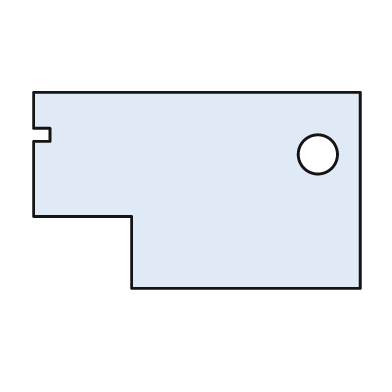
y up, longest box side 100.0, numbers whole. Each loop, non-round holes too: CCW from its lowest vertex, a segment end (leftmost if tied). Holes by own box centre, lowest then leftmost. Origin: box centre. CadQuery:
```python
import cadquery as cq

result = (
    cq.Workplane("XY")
    .moveTo(-20.0, -30.0)
    .lineTo(50.0, -30.0)
    .lineTo(50.0, 30.0)
    .lineTo(-50.0, 30.0)
    .lineTo(-50.0, 19.0)
    .lineTo(-45.0, 19.0)
    .lineTo(-45.0, 15.0)
    .lineTo(-50.0, 15.0)
    .lineTo(-50.0, -8.0)
    .lineTo(-20.0, -8.0)
    .close()
    .moveTo(37.0, 11.0)
    .circle(6.0)
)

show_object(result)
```